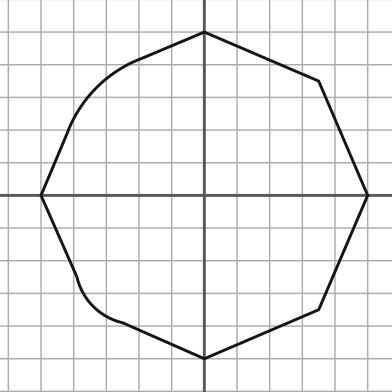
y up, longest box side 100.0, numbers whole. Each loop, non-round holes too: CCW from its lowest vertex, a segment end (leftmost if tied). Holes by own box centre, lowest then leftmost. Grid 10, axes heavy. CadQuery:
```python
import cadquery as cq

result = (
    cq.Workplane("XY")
    .moveTo(0.0, -50.0)
    .lineTo(35.0, -35.0)
    .lineTo(50.0, 0.0)
    .lineTo(35.0, 35.0)
    .lineTo(0.0, 50.0)
    .lineTo(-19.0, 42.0)
    .threePointArc((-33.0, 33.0), (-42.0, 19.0))
    .lineTo(-50.0, 0.0)
    .lineTo(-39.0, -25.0)
    .threePointArc((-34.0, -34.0), (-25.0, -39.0))
    .close()
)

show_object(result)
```